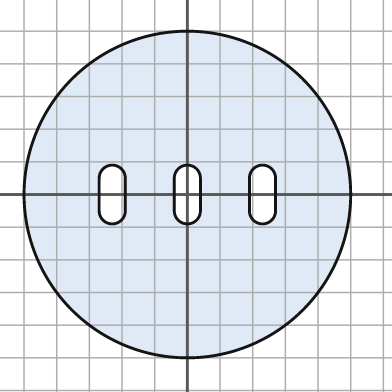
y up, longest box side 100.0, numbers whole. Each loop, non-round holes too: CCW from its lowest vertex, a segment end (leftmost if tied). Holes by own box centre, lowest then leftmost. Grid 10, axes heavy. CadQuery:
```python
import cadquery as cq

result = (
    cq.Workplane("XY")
    .moveTo(0.0, 0.0)
    .circle(50.0)
    .moveTo(-27.0, -5.0)
    .threePointArc((-23.0, -9.0), (-19.0, -5.0))
    .lineTo(-19.0, 5.0)
    .threePointArc((-23.0, 9.0), (-27.0, 5.0))
    .close()
    .moveTo(-4.0, -5.0)
    .threePointArc((0.0, -9.0), (4.0, -5.0))
    .lineTo(4.0, 5.0)
    .threePointArc((0.0, 9.0), (-4.0, 5.0))
    .close()
    .moveTo(19.0, -5.0)
    .threePointArc((23.0, -9.0), (27.0, -5.0))
    .lineTo(27.0, 5.0)
    .threePointArc((23.0, 9.0), (19.0, 5.0))
    .close()
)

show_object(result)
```